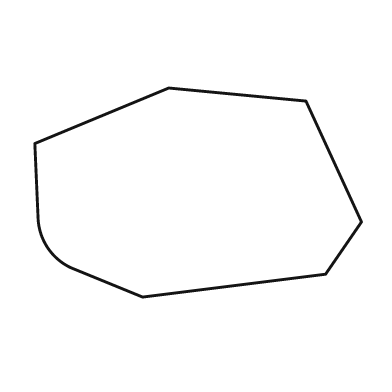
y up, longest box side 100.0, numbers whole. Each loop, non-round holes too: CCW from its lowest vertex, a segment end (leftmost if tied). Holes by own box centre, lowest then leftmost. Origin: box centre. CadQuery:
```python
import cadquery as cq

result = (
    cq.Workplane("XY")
    .moveTo(-17.0, -32.0)
    .lineTo(39.0, -25.0)
    .lineTo(50.0, -9.0)
    .lineTo(33.0, 28.0)
    .lineTo(-9.0, 32.0)
    .lineTo(-50.0, 15.0)
    .lineTo(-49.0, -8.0)
    .threePointArc((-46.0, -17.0), (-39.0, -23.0))
    .close()
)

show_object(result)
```